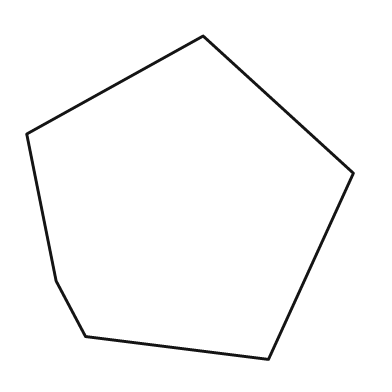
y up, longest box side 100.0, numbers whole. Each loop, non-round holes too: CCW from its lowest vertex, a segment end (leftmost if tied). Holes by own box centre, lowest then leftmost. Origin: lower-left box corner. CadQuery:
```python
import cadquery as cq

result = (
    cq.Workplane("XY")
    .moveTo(74.0, 0.0)
    .lineTo(100.0, 57.0)
    .lineTo(54.0, 99.0)
    .lineTo(0.0, 69.0)
    .lineTo(9.0, 24.0)
    .lineTo(18.0, 7.0)
    .close()
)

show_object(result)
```